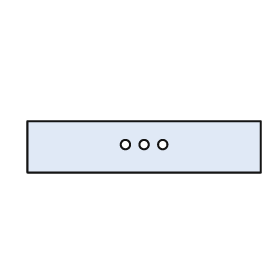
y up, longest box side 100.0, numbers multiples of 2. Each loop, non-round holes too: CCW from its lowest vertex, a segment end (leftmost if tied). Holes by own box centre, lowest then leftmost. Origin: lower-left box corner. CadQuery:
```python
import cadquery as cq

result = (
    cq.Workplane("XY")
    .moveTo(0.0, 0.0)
    .lineTo(100.0, 0.0)
    .lineTo(100.0, 22.0)
    .lineTo(0.0, 22.0)
    .close()
    .moveTo(42.0, 12.0)
    .circle(2.0)
    .moveTo(50.0, 12.0)
    .circle(2.0)
    .moveTo(58.0, 12.0)
    .circle(2.0)
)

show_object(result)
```